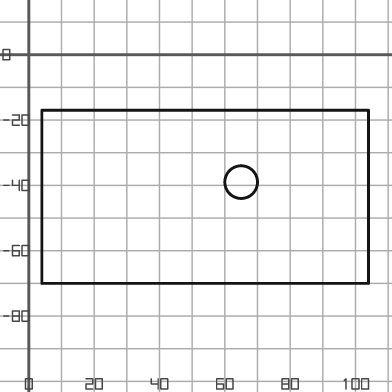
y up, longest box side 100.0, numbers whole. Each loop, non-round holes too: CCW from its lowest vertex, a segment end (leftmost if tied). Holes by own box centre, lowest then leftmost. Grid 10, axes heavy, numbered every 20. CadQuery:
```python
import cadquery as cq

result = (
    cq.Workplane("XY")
    .moveTo(4.0, -70.0)
    .lineTo(104.0, -70.0)
    .lineTo(104.0, -17.0)
    .lineTo(4.0, -17.0)
    .close()
    .moveTo(65.0, -39.0)
    .circle(5.0)
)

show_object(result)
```